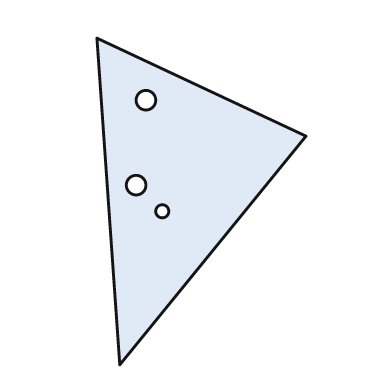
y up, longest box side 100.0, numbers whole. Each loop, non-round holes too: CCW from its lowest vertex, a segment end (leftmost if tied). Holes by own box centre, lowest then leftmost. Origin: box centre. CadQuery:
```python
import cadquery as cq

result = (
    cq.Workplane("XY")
    .moveTo(-25.0, -50.0)
    .lineTo(32.0, 20.0)
    .lineTo(-32.0, 50.0)
    .close()
    .moveTo(-12.0, -3.0)
    .circle(2.0)
    .moveTo(-20.0, 5.0)
    .circle(3.0)
    .moveTo(-17.0, 31.0)
    .circle(3.0)
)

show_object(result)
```